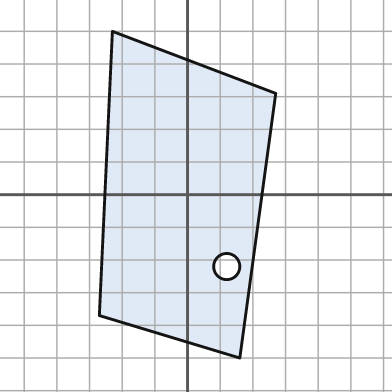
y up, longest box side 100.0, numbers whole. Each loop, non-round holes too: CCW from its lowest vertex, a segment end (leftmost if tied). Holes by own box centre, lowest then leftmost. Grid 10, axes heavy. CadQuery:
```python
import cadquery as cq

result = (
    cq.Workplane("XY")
    .moveTo(16.0, -50.0)
    .lineTo(27.0, 31.0)
    .lineTo(-23.0, 50.0)
    .lineTo(-27.0, -37.0)
    .close()
    .moveTo(12.0, -22.0)
    .circle(4.0)
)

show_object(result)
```